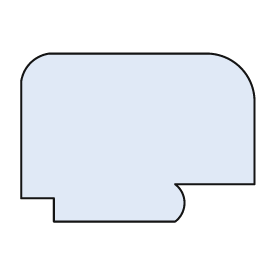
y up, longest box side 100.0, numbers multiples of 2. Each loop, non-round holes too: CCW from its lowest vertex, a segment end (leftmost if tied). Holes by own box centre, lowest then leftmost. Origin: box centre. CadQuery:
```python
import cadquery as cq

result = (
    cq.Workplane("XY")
    .moveTo(-36.0, -36.0)
    .lineTo(16.0, -36.0)
    .threePointArc((20.0, -28.0), (16.0, -20.0))
    .lineTo(50.0, -20.0)
    .lineTo(50.0, 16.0)
    .threePointArc((44.0, 30.0), (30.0, 36.0))
    .lineTo(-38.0, 36.0)
    .threePointArc((-46.0, 32.0), (-50.0, 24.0))
    .lineTo(-50.0, -26.0)
    .lineTo(-36.0, -26.0)
    .close()
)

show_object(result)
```